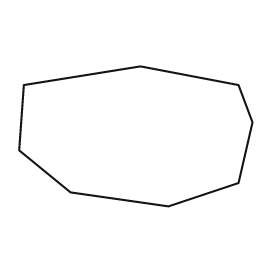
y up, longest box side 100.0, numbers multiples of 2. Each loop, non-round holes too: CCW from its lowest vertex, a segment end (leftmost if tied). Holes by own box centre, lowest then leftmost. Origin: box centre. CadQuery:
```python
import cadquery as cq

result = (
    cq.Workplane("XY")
    .moveTo(14.0, -30.0)
    .lineTo(44.0, -20.0)
    .lineTo(50.0, 6.0)
    .lineTo(44.0, 22.0)
    .lineTo(2.0, 30.0)
    .lineTo(-48.0, 22.0)
    .lineTo(-50.0, -6.0)
    .lineTo(-28.0, -24.0)
    .close()
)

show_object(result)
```